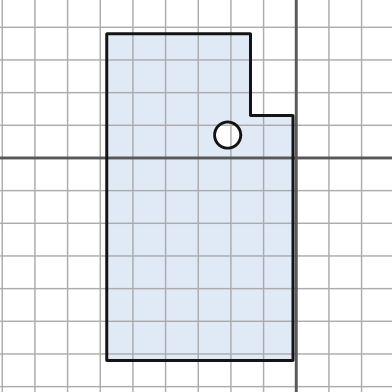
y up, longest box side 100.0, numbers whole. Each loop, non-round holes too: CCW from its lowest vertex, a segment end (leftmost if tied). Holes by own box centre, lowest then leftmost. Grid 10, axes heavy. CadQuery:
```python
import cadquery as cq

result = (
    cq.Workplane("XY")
    .moveTo(-58.0, -62.0)
    .lineTo(-1.0, -62.0)
    .lineTo(-1.0, 13.0)
    .lineTo(-14.0, 13.0)
    .lineTo(-14.0, 38.0)
    .lineTo(-58.0, 38.0)
    .close()
    .moveTo(-21.0, 7.0)
    .circle(4.0)
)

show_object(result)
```